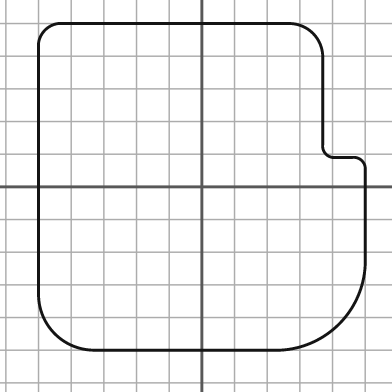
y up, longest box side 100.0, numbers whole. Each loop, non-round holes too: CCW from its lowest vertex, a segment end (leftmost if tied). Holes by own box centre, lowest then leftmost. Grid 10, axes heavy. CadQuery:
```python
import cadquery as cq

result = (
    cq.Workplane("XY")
    .moveTo(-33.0, -50.0)
    .lineTo(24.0, -50.0)
    .threePointArc((42.0, -42.0), (50.0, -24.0))
    .lineTo(50.0, 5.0)
    .threePointArc((49.0, 8.0), (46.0, 9.0))
    .lineTo(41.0, 9.0)
    .threePointArc((38.0, 10.0), (37.0, 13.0))
    .lineTo(37.0, 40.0)
    .threePointArc((34.0, 47.0), (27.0, 50.0))
    .lineTo(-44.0, 50.0)
    .threePointArc((-48.0, 48.0), (-50.0, 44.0))
    .lineTo(-50.0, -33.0)
    .threePointArc((-45.0, -45.0), (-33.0, -50.0))
    .close()
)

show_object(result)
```